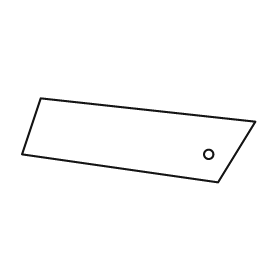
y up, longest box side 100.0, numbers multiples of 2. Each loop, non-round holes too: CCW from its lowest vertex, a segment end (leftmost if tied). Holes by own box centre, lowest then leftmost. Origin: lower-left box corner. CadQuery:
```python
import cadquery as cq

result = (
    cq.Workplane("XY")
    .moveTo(84.0, 0.0)
    .lineTo(100.0, 26.0)
    .lineTo(8.0, 36.0)
    .lineTo(0.0, 12.0)
    .close()
    .moveTo(80.0, 12.0)
    .circle(2.0)
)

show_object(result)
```